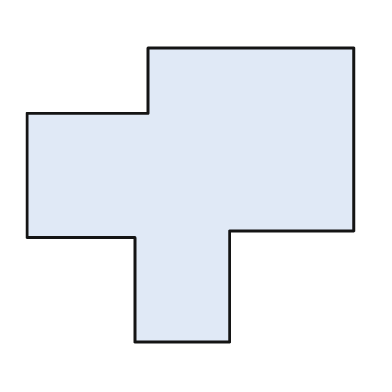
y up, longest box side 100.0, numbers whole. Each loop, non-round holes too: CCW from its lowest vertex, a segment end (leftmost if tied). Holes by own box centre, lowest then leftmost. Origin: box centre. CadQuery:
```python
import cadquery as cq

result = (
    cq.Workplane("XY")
    .moveTo(-17.0, -45.0)
    .lineTo(12.0, -45.0)
    .lineTo(12.0, -11.0)
    .lineTo(50.0, -11.0)
    .lineTo(50.0, 45.0)
    .lineTo(-13.0, 45.0)
    .lineTo(-13.0, 25.0)
    .lineTo(-50.0, 25.0)
    .lineTo(-50.0, -13.0)
    .lineTo(-17.0, -13.0)
    .close()
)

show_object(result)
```